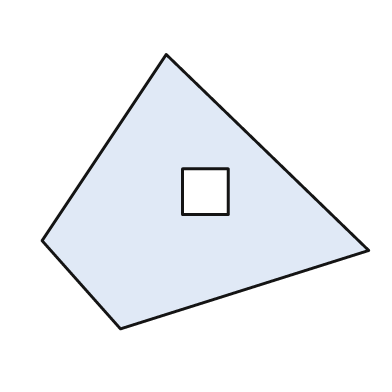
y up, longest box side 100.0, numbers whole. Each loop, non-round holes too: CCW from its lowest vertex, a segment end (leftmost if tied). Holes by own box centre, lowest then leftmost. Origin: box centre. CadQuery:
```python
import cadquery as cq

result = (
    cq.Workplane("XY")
    .moveTo(-26.0, -42.0)
    .lineTo(50.0, -18.0)
    .lineTo(-12.0, 42.0)
    .lineTo(-50.0, -15.0)
    .close()
    .moveTo(-7.0, -7.0)
    .lineTo(7.0, -7.0)
    .lineTo(7.0, 7.0)
    .lineTo(-7.0, 7.0)
    .close()
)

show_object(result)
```